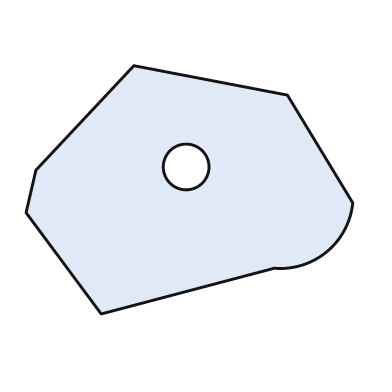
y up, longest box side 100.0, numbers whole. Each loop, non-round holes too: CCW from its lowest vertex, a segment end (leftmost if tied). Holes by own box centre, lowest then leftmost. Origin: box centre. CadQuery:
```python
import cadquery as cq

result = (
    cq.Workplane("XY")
    .moveTo(-27.0, -38.0)
    .lineTo(26.0, -24.0)
    .threePointArc((42.0, -19.0), (50.0, -4.0))
    .lineTo(30.0, 29.0)
    .lineTo(-17.0, 38.0)
    .lineTo(-47.0, 6.0)
    .lineTo(-50.0, -7.0)
    .close()
    .moveTo(-1.0, 7.0)
    .circle(7.0)
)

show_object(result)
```